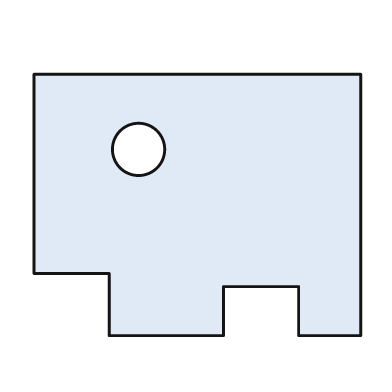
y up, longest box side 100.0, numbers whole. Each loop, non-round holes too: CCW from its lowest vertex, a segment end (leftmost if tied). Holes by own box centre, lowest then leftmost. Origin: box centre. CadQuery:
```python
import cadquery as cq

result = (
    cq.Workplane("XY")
    .moveTo(-27.0, -40.0)
    .lineTo(8.0, -40.0)
    .lineTo(8.0, -25.0)
    .lineTo(31.0, -25.0)
    .lineTo(31.0, -40.0)
    .lineTo(50.0, -40.0)
    .lineTo(50.0, 40.0)
    .lineTo(-50.0, 40.0)
    .lineTo(-50.0, -21.0)
    .lineTo(-27.0, -21.0)
    .close()
    .moveTo(-18.0, 17.0)
    .circle(8.0)
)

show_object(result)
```